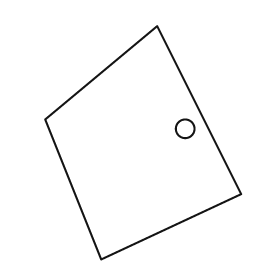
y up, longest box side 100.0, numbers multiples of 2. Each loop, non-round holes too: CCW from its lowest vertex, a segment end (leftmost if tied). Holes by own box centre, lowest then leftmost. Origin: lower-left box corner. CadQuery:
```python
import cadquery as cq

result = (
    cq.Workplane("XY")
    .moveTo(24.0, 0.0)
    .lineTo(84.0, 28.0)
    .lineTo(48.0, 100.0)
    .lineTo(0.0, 60.0)
    .close()
    .moveTo(60.0, 56.0)
    .circle(4.0)
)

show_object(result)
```